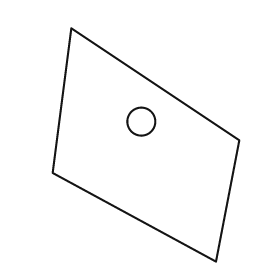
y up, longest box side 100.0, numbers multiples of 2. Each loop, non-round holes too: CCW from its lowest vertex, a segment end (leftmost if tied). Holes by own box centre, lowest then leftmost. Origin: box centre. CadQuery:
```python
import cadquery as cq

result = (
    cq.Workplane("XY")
    .moveTo(30.0, -50.0)
    .lineTo(40.0, 2.0)
    .lineTo(-32.0, 50.0)
    .lineTo(-40.0, -12.0)
    .close()
    .moveTo(-2.0, 10.0)
    .circle(6.0)
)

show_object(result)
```